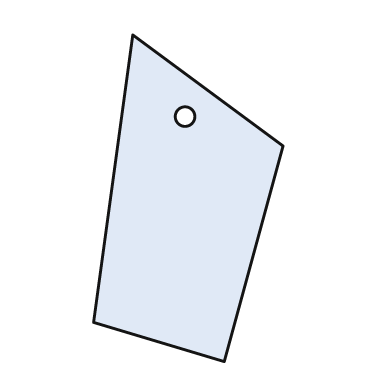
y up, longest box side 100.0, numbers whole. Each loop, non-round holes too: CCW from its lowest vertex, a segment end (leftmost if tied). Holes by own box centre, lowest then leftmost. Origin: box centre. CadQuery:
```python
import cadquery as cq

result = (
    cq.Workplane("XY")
    .moveTo(11.0, -50.0)
    .lineTo(29.0, 16.0)
    .lineTo(-17.0, 50.0)
    .lineTo(-29.0, -38.0)
    .close()
    .moveTo(-1.0, 25.0)
    .circle(3.0)
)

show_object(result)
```